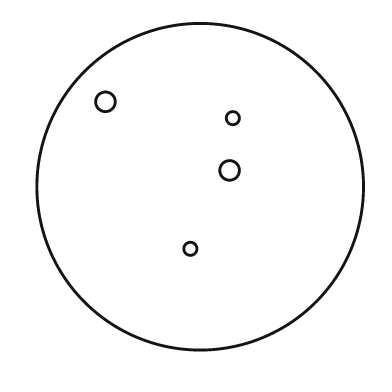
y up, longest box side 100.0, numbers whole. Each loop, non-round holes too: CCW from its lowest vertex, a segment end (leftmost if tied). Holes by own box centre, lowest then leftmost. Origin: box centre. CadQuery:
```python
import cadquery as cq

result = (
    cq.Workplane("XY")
    .moveTo(0.0, 0.0)
    .circle(50.0)
    .moveTo(-3.0, -19.0)
    .circle(2.0)
    .moveTo(9.0, 5.0)
    .circle(3.0)
    .moveTo(10.0, 21.0)
    .circle(2.0)
    .moveTo(-29.0, 26.0)
    .circle(3.0)
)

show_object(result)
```